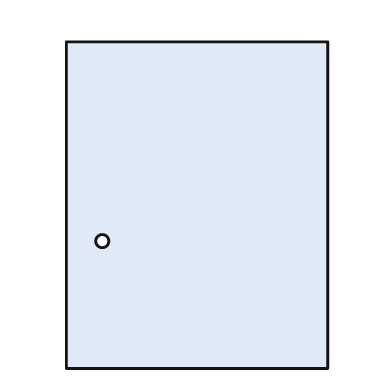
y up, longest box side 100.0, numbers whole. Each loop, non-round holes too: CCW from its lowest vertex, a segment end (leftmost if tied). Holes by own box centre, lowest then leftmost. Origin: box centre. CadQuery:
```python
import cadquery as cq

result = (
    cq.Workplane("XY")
    .moveTo(-40.0, -50.0)
    .lineTo(40.0, -50.0)
    .lineTo(40.0, 50.0)
    .lineTo(-40.0, 50.0)
    .close()
    .moveTo(-29.0, -11.0)
    .circle(2.0)
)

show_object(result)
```